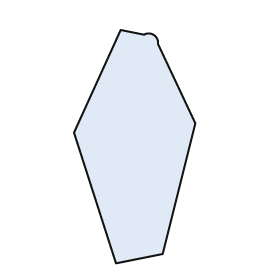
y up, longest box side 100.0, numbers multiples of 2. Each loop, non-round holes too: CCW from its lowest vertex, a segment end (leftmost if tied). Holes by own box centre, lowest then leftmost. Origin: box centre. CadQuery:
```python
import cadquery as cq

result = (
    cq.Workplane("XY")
    .moveTo(-8.0, -50.0)
    .lineTo(12.0, -46.0)
    .lineTo(26.0, 10.0)
    .lineTo(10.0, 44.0)
    .threePointArc((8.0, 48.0), (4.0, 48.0))
    .lineTo(-6.0, 50.0)
    .lineTo(-26.0, 6.0)
    .close()
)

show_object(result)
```